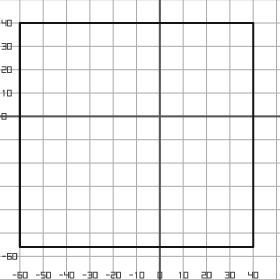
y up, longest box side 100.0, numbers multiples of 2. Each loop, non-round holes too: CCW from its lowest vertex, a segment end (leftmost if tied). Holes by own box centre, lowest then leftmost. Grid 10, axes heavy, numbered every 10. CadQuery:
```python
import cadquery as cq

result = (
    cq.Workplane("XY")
    .moveTo(-60.0, -56.0)
    .lineTo(40.0, -56.0)
    .lineTo(40.0, 40.0)
    .lineTo(-60.0, 40.0)
    .close()
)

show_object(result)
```